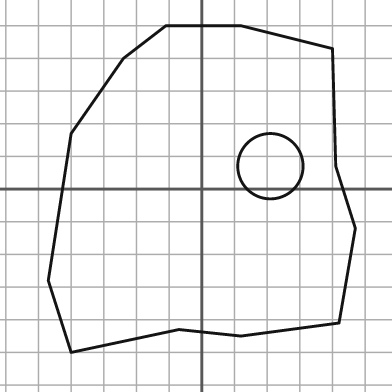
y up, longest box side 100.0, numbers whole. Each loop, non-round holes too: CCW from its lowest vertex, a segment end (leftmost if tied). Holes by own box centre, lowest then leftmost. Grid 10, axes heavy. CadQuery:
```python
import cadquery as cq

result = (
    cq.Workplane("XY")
    .moveTo(-40.0, -50.0)
    .lineTo(-7.0, -43.0)
    .lineTo(12.0, -45.0)
    .lineTo(42.0, -41.0)
    .lineTo(47.0, -12.0)
    .lineTo(41.0, 7.0)
    .lineTo(40.0, 43.0)
    .lineTo(12.0, 50.0)
    .lineTo(-11.0, 50.0)
    .lineTo(-24.0, 40.0)
    .lineTo(-40.0, 17.0)
    .lineTo(-47.0, -28.0)
    .close()
    .moveTo(21.0, 7.0)
    .circle(10.0)
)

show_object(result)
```